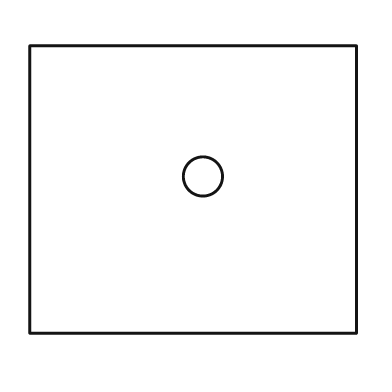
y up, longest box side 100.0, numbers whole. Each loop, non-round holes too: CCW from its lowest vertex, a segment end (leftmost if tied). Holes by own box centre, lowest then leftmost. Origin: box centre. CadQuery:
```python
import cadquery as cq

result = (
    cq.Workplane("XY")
    .moveTo(-50.0, -44.0)
    .lineTo(50.0, -44.0)
    .lineTo(50.0, 44.0)
    .lineTo(-50.0, 44.0)
    .close()
    .moveTo(3.0, 4.0)
    .circle(6.0)
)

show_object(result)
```